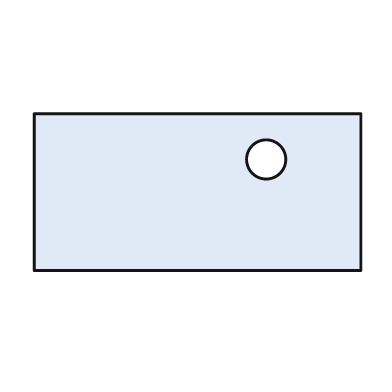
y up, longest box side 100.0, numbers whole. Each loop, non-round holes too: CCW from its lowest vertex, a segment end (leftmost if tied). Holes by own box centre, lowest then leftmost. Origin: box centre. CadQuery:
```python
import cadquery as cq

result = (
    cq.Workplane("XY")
    .moveTo(-50.0, -24.0)
    .lineTo(50.0, -24.0)
    .lineTo(50.0, 24.0)
    .lineTo(-50.0, 24.0)
    .close()
    .moveTo(21.0, 10.0)
    .circle(6.0)
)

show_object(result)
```